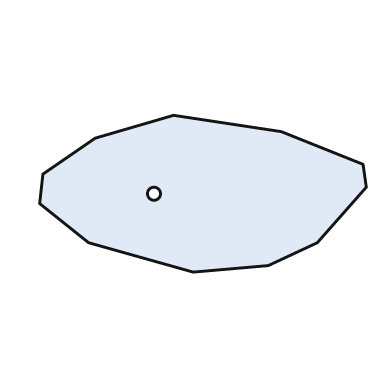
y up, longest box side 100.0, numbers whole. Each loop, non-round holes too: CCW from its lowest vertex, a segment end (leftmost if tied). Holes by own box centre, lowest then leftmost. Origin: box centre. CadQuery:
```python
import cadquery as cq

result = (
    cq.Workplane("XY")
    .moveTo(-3.0, -24.0)
    .lineTo(20.0, -22.0)
    .lineTo(35.0, -15.0)
    .lineTo(50.0, 2.0)
    .lineTo(49.0, 9.0)
    .lineTo(24.0, 19.0)
    .lineTo(-9.0, 24.0)
    .lineTo(-33.0, 17.0)
    .lineTo(-49.0, 6.0)
    .lineTo(-50.0, -3.0)
    .lineTo(-35.0, -15.0)
    .close()
    .moveTo(-15.0, 0.0)
    .circle(2.0)
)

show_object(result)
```